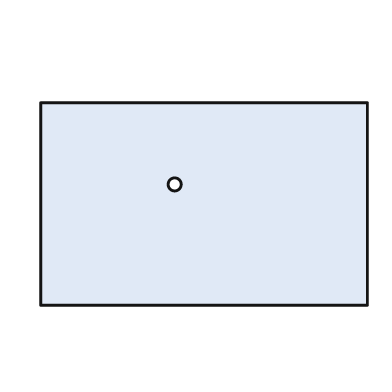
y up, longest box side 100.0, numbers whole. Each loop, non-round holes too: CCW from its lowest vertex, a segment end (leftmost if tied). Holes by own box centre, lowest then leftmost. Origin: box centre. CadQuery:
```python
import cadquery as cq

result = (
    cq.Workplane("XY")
    .moveTo(-50.0, -31.0)
    .lineTo(50.0, -31.0)
    .lineTo(50.0, 31.0)
    .lineTo(-50.0, 31.0)
    .close()
    .moveTo(-9.0, 6.0)
    .circle(2.0)
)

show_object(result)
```